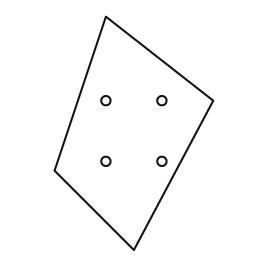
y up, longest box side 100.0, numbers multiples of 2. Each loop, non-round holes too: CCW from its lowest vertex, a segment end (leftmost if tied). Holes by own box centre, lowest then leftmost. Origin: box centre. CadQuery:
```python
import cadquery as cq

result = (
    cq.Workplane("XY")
    .moveTo(0.0, -50.0)
    .lineTo(34.0, 14.0)
    .lineTo(-12.0, 50.0)
    .lineTo(-34.0, -16.0)
    .close()
    .moveTo(-12.0, -12.0)
    .circle(2.0)
    .moveTo(12.0, -12.0)
    .circle(2.0)
    .moveTo(-12.0, 14.0)
    .circle(2.0)
    .moveTo(12.0, 14.0)
    .circle(2.0)
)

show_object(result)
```